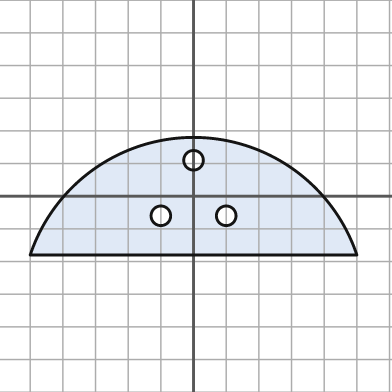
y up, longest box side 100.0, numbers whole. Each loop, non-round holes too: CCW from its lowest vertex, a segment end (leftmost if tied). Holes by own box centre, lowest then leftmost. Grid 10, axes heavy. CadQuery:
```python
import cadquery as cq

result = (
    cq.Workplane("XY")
    .moveTo(-50.0, -18.0)
    .lineTo(50.0, -18.0)
    .threePointArc((0.0, 18.0), (-50.0, -18.0))
    .close()
    .moveTo(-10.0, -6.0)
    .circle(3.0)
    .moveTo(10.0, -6.0)
    .circle(3.0)
    .moveTo(0.0, 11.0)
    .circle(3.0)
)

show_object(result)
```